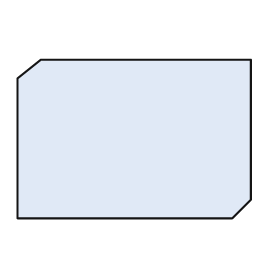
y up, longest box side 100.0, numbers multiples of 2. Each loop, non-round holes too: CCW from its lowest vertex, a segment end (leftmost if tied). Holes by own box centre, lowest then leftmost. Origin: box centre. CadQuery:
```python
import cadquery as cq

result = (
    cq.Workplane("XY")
    .moveTo(-50.0, -34.0)
    .lineTo(42.0, -34.0)
    .lineTo(50.0, -26.0)
    .lineTo(50.0, 34.0)
    .lineTo(-40.0, 34.0)
    .lineTo(-50.0, 26.0)
    .close()
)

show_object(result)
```